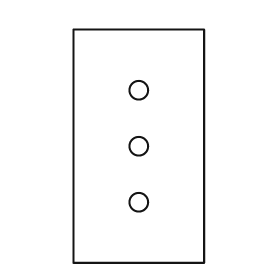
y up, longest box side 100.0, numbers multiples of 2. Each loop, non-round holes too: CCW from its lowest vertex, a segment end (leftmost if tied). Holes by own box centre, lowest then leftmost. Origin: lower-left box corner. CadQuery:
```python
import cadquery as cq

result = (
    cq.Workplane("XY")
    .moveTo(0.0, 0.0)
    .lineTo(56.0, 0.0)
    .lineTo(56.0, 100.0)
    .lineTo(0.0, 100.0)
    .close()
    .moveTo(28.0, 26.0)
    .circle(4.0)
    .moveTo(28.0, 50.0)
    .circle(4.0)
    .moveTo(28.0, 74.0)
    .circle(4.0)
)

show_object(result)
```